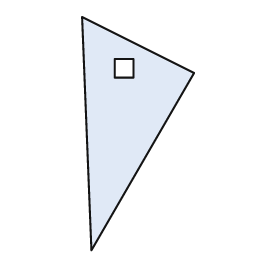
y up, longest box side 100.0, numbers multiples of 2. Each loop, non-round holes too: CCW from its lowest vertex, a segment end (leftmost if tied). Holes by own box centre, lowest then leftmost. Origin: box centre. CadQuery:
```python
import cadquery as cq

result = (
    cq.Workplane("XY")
    .moveTo(-20.0, -50.0)
    .lineTo(24.0, 26.0)
    .lineTo(-24.0, 50.0)
    .close()
    .moveTo(-10.0, 24.0)
    .lineTo(-2.0, 24.0)
    .lineTo(-2.0, 32.0)
    .lineTo(-10.0, 32.0)
    .close()
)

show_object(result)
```